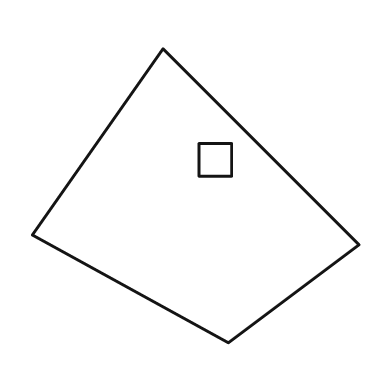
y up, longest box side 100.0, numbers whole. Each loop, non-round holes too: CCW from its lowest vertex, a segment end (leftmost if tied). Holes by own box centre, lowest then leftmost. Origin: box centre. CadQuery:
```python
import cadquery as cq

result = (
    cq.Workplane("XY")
    .moveTo(10.0, -45.0)
    .lineTo(50.0, -15.0)
    .lineTo(-10.0, 45.0)
    .lineTo(-50.0, -12.0)
    .close()
    .moveTo(1.0, 6.0)
    .lineTo(11.0, 6.0)
    .lineTo(11.0, 16.0)
    .lineTo(1.0, 16.0)
    .close()
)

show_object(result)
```